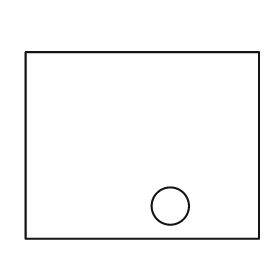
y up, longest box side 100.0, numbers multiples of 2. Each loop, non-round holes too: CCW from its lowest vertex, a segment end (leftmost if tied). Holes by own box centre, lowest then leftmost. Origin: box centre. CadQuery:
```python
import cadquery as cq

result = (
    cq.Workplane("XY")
    .moveTo(-50.0, -40.0)
    .lineTo(50.0, -40.0)
    .lineTo(50.0, 40.0)
    .lineTo(-50.0, 40.0)
    .close()
    .moveTo(12.0, -26.0)
    .circle(8.0)
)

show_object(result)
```